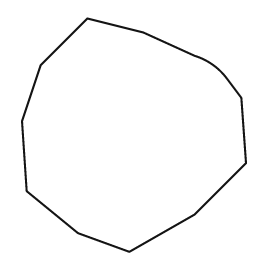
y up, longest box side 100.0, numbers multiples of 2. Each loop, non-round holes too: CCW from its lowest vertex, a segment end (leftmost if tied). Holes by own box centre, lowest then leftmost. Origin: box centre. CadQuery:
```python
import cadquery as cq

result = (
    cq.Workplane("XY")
    .moveTo(-2.0, -50.0)
    .lineTo(26.0, -34.0)
    .lineTo(48.0, -12.0)
    .lineTo(46.0, 16.0)
    .lineTo(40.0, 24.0)
    .threePointArc((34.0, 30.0), (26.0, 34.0))
    .lineTo(4.0, 44.0)
    .lineTo(-20.0, 50.0)
    .lineTo(-40.0, 30.0)
    .lineTo(-48.0, 6.0)
    .lineTo(-46.0, -24.0)
    .lineTo(-24.0, -42.0)
    .close()
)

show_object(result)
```